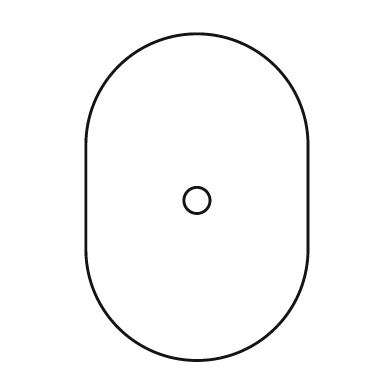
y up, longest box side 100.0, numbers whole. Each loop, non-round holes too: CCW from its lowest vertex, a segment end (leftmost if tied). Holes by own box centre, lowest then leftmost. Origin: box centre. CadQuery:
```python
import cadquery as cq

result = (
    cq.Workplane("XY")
    .moveTo(-34.0, -16.0)
    .threePointArc((0.0, -50.0), (34.0, -16.0))
    .lineTo(34.0, 16.0)
    .threePointArc((0.0, 50.0), (-34.0, 16.0))
    .close()
    .moveTo(0.0, -1.0)
    .circle(4.0)
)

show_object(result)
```